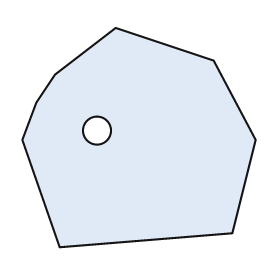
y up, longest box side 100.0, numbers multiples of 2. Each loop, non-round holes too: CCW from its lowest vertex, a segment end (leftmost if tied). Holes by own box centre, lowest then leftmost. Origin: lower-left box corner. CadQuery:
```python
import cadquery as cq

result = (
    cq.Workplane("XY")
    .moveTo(16.0, 0.0)
    .lineTo(90.0, 6.0)
    .lineTo(100.0, 46.0)
    .lineTo(82.0, 80.0)
    .lineTo(40.0, 94.0)
    .lineTo(14.0, 74.0)
    .lineTo(6.0, 62.0)
    .lineTo(0.0, 46.0)
    .close()
    .moveTo(32.0, 50.0)
    .circle(6.0)
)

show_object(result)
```